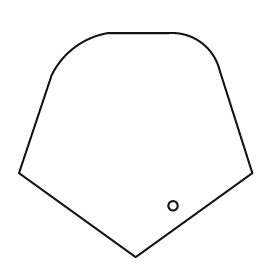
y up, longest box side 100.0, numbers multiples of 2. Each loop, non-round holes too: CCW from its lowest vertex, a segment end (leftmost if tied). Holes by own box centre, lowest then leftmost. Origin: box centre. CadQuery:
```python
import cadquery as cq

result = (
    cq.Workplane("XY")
    .moveTo(0.0, -48.0)
    .lineTo(50.0, -12.0)
    .lineTo(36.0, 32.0)
    .threePointArc((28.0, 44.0), (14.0, 48.0))
    .lineTo(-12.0, 48.0)
    .threePointArc((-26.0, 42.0), (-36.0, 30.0))
    .lineTo(-50.0, -12.0)
    .close()
    .moveTo(16.0, -26.0)
    .circle(2.0)
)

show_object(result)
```